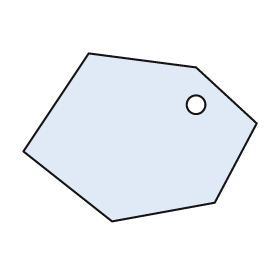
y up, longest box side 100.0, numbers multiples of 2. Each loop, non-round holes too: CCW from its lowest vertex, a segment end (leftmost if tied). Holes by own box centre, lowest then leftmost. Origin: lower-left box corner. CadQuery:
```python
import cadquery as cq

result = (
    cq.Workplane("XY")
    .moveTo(38.0, 0.0)
    .lineTo(82.0, 8.0)
    .lineTo(100.0, 42.0)
    .lineTo(74.0, 66.0)
    .lineTo(28.0, 72.0)
    .lineTo(0.0, 30.0)
    .close()
    .moveTo(74.0, 50.0)
    .circle(4.0)
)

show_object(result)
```